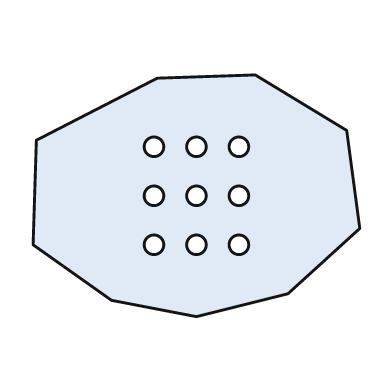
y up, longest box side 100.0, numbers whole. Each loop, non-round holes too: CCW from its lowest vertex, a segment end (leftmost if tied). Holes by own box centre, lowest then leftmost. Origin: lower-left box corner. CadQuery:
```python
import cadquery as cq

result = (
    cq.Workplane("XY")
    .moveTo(50.0, 0.0)
    .lineTo(78.0, 7.0)
    .lineTo(100.0, 27.0)
    .lineTo(96.0, 57.0)
    .lineTo(68.0, 74.0)
    .lineTo(38.0, 73.0)
    .lineTo(1.0, 54.0)
    .lineTo(0.0, 22.0)
    .lineTo(24.0, 5.0)
    .close()
    .moveTo(37.0, 22.0)
    .circle(3.0)
    .moveTo(50.0, 22.0)
    .circle(3.0)
    .moveTo(63.0, 22.0)
    .circle(3.0)
    .moveTo(37.0, 37.0)
    .circle(3.0)
    .moveTo(50.0, 37.0)
    .circle(3.0)
    .moveTo(63.0, 37.0)
    .circle(3.0)
    .moveTo(37.0, 52.0)
    .circle(3.0)
    .moveTo(50.0, 52.0)
    .circle(3.0)
    .moveTo(63.0, 52.0)
    .circle(3.0)
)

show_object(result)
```